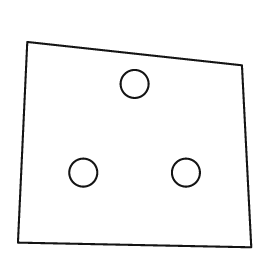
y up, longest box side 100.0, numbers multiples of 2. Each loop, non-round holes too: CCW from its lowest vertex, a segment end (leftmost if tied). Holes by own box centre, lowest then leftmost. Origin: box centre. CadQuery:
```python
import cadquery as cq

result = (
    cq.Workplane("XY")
    .moveTo(50.0, -44.0)
    .lineTo(46.0, 34.0)
    .lineTo(-46.0, 44.0)
    .lineTo(-50.0, -42.0)
    .close()
    .moveTo(-22.0, -12.0)
    .circle(6.0)
    .moveTo(22.0, -12.0)
    .circle(6.0)
    .moveTo(0.0, 26.0)
    .circle(6.0)
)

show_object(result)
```